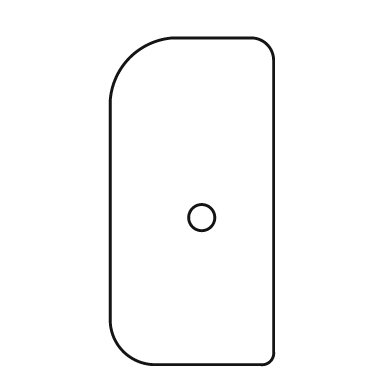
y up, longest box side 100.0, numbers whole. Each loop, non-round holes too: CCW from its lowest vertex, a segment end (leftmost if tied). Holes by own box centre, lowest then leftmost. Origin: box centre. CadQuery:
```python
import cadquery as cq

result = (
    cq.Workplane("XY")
    .moveTo(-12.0, -50.0)
    .lineTo(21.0, -50.0)
    .threePointArc((24.0, -49.0), (25.0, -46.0))
    .lineTo(25.0, 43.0)
    .threePointArc((23.0, 48.0), (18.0, 50.0))
    .lineTo(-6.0, 50.0)
    .threePointArc((-19.0, 44.0), (-25.0, 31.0))
    .lineTo(-25.0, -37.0)
    .threePointArc((-21.0, -46.0), (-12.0, -50.0))
    .close()
    .moveTo(3.0, -5.0)
    .circle(4.0)
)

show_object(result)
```